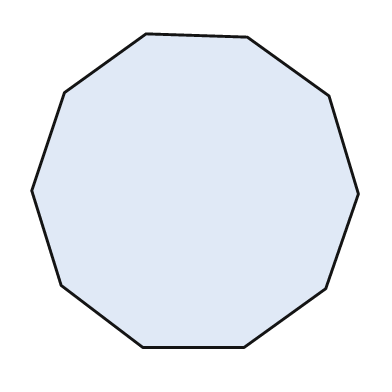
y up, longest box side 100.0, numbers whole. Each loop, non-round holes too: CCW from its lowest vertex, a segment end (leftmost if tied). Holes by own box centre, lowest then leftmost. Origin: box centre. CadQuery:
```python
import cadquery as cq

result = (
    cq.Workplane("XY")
    .moveTo(-16.0, -48.0)
    .lineTo(15.0, -48.0)
    .lineTo(40.0, -30.0)
    .lineTo(50.0, -1.0)
    .lineTo(41.0, 29.0)
    .lineTo(16.0, 47.0)
    .lineTo(-15.0, 48.0)
    .lineTo(-40.0, 30.0)
    .lineTo(-50.0, 0.0)
    .lineTo(-41.0, -29.0)
    .close()
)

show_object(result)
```